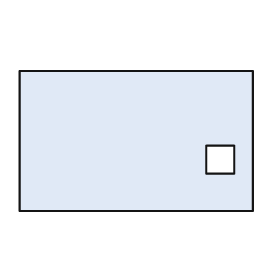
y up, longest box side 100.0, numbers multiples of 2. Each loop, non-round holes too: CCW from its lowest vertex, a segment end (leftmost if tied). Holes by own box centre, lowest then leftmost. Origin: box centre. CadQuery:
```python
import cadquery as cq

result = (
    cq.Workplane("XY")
    .moveTo(-50.0, -30.0)
    .lineTo(50.0, -30.0)
    .lineTo(50.0, 30.0)
    .lineTo(-50.0, 30.0)
    .close()
    .moveTo(30.0, -14.0)
    .lineTo(42.0, -14.0)
    .lineTo(42.0, -2.0)
    .lineTo(30.0, -2.0)
    .close()
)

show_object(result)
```